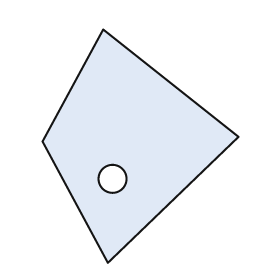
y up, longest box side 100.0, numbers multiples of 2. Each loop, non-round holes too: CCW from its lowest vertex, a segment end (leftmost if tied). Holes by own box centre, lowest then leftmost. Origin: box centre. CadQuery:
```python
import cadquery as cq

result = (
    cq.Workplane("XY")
    .moveTo(-14.0, -50.0)
    .lineTo(42.0, 4.0)
    .lineTo(-16.0, 50.0)
    .lineTo(-42.0, 2.0)
    .close()
    .moveTo(-12.0, -14.0)
    .circle(6.0)
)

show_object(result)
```